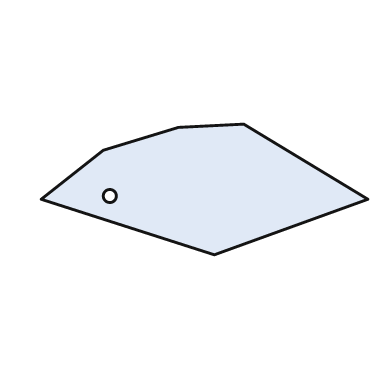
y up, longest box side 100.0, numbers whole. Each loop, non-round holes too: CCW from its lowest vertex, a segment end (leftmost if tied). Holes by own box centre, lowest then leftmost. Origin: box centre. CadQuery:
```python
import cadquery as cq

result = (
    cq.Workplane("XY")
    .moveTo(3.0, -20.0)
    .lineTo(50.0, -3.0)
    .lineTo(12.0, 20.0)
    .lineTo(-8.0, 19.0)
    .lineTo(-31.0, 12.0)
    .lineTo(-50.0, -3.0)
    .close()
    .moveTo(-29.0, -2.0)
    .circle(2.0)
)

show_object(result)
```